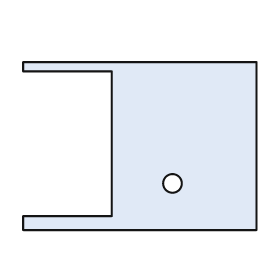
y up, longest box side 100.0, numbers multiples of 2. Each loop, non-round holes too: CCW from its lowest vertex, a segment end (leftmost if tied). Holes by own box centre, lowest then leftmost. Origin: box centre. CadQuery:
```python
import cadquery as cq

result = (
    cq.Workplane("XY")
    .moveTo(-50.0, -36.0)
    .lineTo(50.0, -36.0)
    .lineTo(50.0, 36.0)
    .lineTo(-50.0, 36.0)
    .lineTo(-50.0, 32.0)
    .lineTo(-12.0, 32.0)
    .lineTo(-12.0, -30.0)
    .lineTo(-50.0, -30.0)
    .close()
    .moveTo(14.0, -16.0)
    .circle(4.0)
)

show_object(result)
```